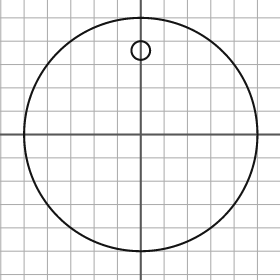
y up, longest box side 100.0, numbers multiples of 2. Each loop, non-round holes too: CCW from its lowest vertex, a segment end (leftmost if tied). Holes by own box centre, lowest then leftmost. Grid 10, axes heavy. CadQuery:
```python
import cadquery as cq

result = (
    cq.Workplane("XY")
    .moveTo(0.0, 0.0)
    .circle(50.0)
    .moveTo(0.0, 36.0)
    .circle(4.0)
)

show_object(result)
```